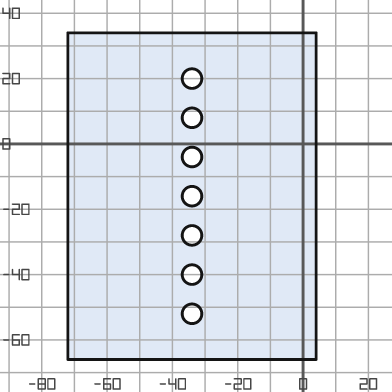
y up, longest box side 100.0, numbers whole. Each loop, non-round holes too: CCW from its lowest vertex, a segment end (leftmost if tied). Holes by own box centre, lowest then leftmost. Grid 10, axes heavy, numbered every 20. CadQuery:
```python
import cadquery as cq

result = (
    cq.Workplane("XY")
    .moveTo(-72.0, -66.0)
    .lineTo(4.0, -66.0)
    .lineTo(4.0, 34.0)
    .lineTo(-72.0, 34.0)
    .close()
    .moveTo(-34.0, -52.0)
    .circle(3.0)
    .moveTo(-34.0, -40.0)
    .circle(3.0)
    .moveTo(-34.0, -28.0)
    .circle(3.0)
    .moveTo(-34.0, -16.0)
    .circle(3.0)
    .moveTo(-34.0, -4.0)
    .circle(3.0)
    .moveTo(-34.0, 8.0)
    .circle(3.0)
    .moveTo(-34.0, 20.0)
    .circle(3.0)
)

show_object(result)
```